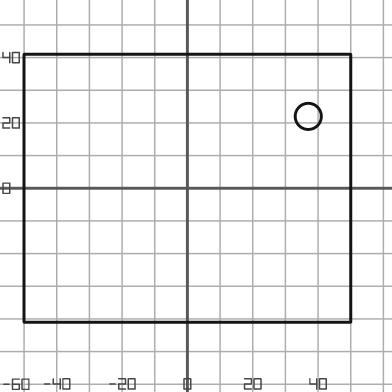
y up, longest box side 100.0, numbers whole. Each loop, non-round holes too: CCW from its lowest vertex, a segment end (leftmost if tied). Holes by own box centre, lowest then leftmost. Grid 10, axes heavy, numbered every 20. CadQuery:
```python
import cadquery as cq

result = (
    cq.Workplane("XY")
    .moveTo(-50.0, -41.0)
    .lineTo(50.0, -41.0)
    .lineTo(50.0, 41.0)
    .lineTo(-50.0, 41.0)
    .close()
    .moveTo(37.0, 22.0)
    .circle(4.0)
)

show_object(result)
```